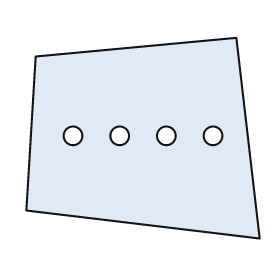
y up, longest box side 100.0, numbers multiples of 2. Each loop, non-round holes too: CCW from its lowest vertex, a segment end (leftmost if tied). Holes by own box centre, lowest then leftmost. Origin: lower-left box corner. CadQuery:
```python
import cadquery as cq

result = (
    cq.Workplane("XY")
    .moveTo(100.0, 0.0)
    .lineTo(90.0, 86.0)
    .lineTo(4.0, 78.0)
    .lineTo(0.0, 12.0)
    .close()
    .moveTo(20.0, 44.0)
    .circle(4.0)
    .moveTo(40.0, 44.0)
    .circle(4.0)
    .moveTo(60.0, 44.0)
    .circle(4.0)
    .moveTo(80.0, 44.0)
    .circle(4.0)
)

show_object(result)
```